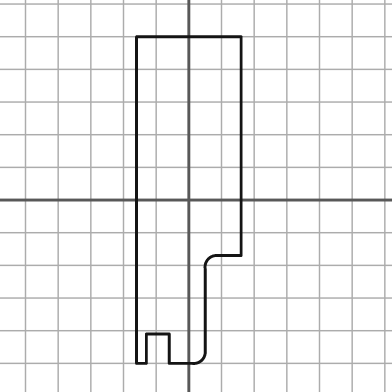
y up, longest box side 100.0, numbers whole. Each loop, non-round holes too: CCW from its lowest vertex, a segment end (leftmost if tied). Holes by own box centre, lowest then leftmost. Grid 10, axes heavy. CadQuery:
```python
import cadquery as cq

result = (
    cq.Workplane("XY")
    .moveTo(-16.0, -50.0)
    .lineTo(-13.0, -50.0)
    .lineTo(-13.0, -41.0)
    .lineTo(-6.0, -41.0)
    .lineTo(-6.0, -50.0)
    .lineTo(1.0, -50.0)
    .threePointArc((4.0, -49.0), (5.0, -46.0))
    .lineTo(5.0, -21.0)
    .threePointArc((6.0, -18.0), (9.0, -17.0))
    .lineTo(16.0, -17.0)
    .lineTo(16.0, 50.0)
    .lineTo(-16.0, 50.0)
    .close()
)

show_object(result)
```